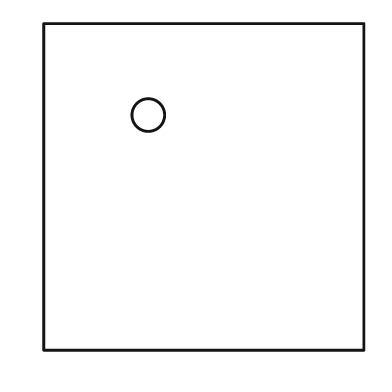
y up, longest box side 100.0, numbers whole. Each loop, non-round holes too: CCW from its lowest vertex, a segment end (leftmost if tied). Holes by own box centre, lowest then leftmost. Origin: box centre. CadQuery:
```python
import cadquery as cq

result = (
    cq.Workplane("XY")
    .moveTo(-49.0, -50.0)
    .lineTo(49.0, -50.0)
    .lineTo(49.0, 50.0)
    .lineTo(-49.0, 50.0)
    .close()
    .moveTo(-17.0, 22.0)
    .circle(5.0)
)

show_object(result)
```